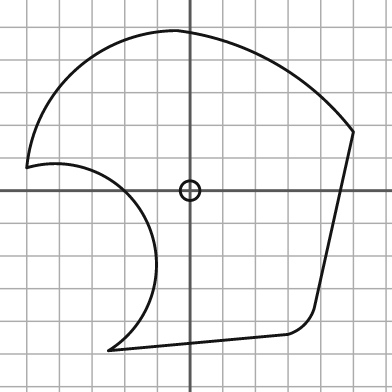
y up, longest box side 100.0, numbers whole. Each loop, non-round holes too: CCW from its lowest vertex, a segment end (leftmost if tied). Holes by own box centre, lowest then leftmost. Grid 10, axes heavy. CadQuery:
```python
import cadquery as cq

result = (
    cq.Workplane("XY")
    .moveTo(-25.0, -49.0)
    .lineTo(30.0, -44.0)
    .threePointArc((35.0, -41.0), (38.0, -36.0))
    .lineTo(50.0, 18.0)
    .threePointArc((26.0, 39.0), (-4.0, 49.0))
    .threePointArc((-35.0, 37.0), (-50.0, 7.0))
    .threePointArc((-13.0, -10.0), (-25.0, -49.0))
    .close()
    .moveTo(0.0, 0.0)
    .circle(3.0)
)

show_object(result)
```